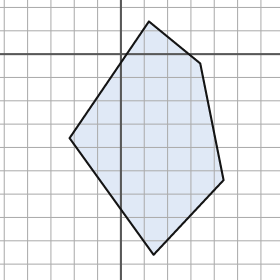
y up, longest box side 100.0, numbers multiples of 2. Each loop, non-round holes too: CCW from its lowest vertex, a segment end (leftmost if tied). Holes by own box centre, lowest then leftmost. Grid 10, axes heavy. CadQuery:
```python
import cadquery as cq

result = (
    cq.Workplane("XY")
    .moveTo(14.0, -86.0)
    .lineTo(44.0, -54.0)
    .lineTo(34.0, -4.0)
    .lineTo(12.0, 14.0)
    .lineTo(-22.0, -36.0)
    .close()
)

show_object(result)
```